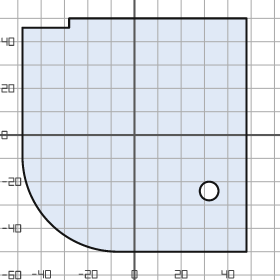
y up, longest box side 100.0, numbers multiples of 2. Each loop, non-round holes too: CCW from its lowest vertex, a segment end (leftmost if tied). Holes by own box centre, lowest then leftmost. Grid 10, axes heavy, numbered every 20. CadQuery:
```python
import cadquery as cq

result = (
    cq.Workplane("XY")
    .moveTo(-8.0, -50.0)
    .lineTo(48.0, -50.0)
    .lineTo(48.0, 50.0)
    .lineTo(-28.0, 50.0)
    .lineTo(-28.0, 46.0)
    .lineTo(-48.0, 46.0)
    .lineTo(-48.0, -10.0)
    .threePointArc((-36.0, -38.0), (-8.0, -50.0))
    .close()
    .moveTo(32.0, -24.0)
    .circle(4.0)
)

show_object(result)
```